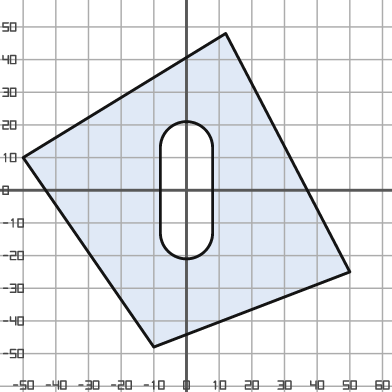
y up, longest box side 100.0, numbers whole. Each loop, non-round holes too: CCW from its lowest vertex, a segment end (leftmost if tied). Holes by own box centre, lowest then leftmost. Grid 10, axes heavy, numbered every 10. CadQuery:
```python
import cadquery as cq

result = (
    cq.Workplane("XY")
    .moveTo(-10.0, -48.0)
    .lineTo(50.0, -25.0)
    .lineTo(12.0, 48.0)
    .lineTo(-50.0, 10.0)
    .close()
    .moveTo(-8.0, -13.0)
    .threePointArc((0.0, -21.0), (8.0, -13.0))
    .lineTo(8.0, 13.0)
    .threePointArc((0.0, 21.0), (-8.0, 13.0))
    .close()
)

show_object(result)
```